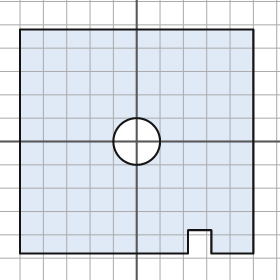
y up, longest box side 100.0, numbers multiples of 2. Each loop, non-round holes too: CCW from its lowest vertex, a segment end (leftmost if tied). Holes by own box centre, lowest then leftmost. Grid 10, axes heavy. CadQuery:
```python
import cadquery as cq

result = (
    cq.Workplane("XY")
    .moveTo(-50.0, -48.0)
    .lineTo(22.0, -48.0)
    .lineTo(22.0, -38.0)
    .lineTo(32.0, -38.0)
    .lineTo(32.0, -48.0)
    .lineTo(50.0, -48.0)
    .lineTo(50.0, 48.0)
    .lineTo(-50.0, 48.0)
    .close()
    .moveTo(0.0, 0.0)
    .circle(10.0)
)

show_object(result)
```